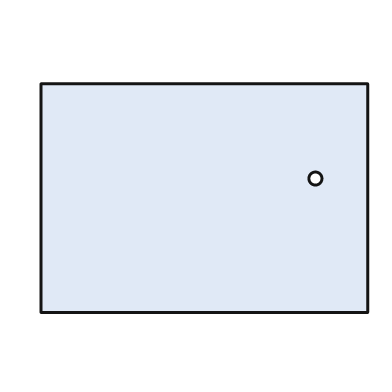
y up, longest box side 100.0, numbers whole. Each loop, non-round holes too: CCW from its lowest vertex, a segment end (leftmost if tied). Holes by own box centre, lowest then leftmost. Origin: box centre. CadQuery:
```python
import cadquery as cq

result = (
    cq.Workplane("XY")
    .moveTo(-50.0, -35.0)
    .lineTo(50.0, -35.0)
    .lineTo(50.0, 35.0)
    .lineTo(-50.0, 35.0)
    .close()
    .moveTo(34.0, 6.0)
    .circle(2.0)
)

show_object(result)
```